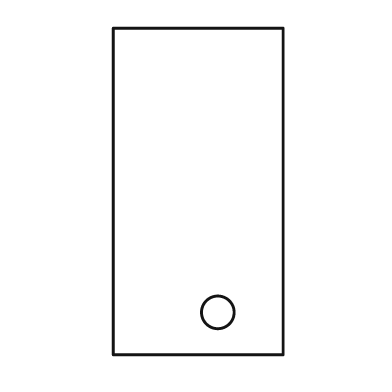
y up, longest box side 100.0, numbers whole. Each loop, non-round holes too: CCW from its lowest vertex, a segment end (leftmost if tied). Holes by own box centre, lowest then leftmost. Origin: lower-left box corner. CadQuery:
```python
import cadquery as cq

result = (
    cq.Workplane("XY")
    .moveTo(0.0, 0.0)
    .lineTo(52.0, 0.0)
    .lineTo(52.0, 100.0)
    .lineTo(0.0, 100.0)
    .close()
    .moveTo(32.0, 13.0)
    .circle(5.0)
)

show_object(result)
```